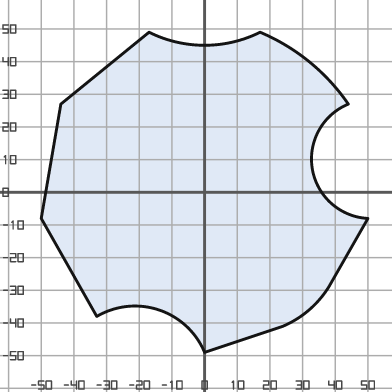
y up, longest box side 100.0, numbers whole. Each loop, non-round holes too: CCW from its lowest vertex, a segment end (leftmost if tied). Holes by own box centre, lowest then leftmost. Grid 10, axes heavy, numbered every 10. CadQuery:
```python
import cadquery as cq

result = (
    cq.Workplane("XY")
    .moveTo(0.0, -49.0)
    .lineTo(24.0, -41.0)
    .threePointArc((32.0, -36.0), (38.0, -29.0))
    .lineTo(50.0, -8.0)
    .threePointArc((33.0, 7.0), (44.0, 27.0))
    .threePointArc((32.0, 40.0), (17.0, 49.0))
    .threePointArc((0.0, 45.0), (-17.0, 49.0))
    .lineTo(-44.0, 27.0)
    .lineTo(-50.0, -8.0)
    .lineTo(-33.0, -38.0)
    .threePointArc((-14.0, -36.0), (0.0, -49.0))
    .close()
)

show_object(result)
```